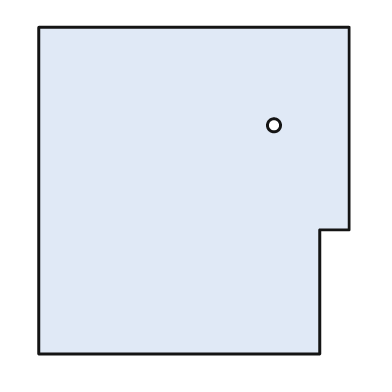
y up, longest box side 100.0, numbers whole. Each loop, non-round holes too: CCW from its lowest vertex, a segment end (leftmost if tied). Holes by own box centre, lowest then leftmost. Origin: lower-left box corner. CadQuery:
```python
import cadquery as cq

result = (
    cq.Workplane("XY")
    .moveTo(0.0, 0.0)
    .lineTo(86.0, 0.0)
    .lineTo(86.0, 38.0)
    .lineTo(95.0, 38.0)
    .lineTo(95.0, 100.0)
    .lineTo(0.0, 100.0)
    .close()
    .moveTo(72.0, 70.0)
    .circle(2.0)
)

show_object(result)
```